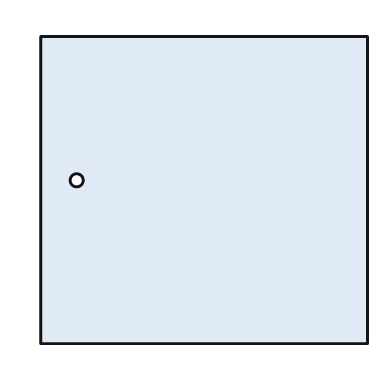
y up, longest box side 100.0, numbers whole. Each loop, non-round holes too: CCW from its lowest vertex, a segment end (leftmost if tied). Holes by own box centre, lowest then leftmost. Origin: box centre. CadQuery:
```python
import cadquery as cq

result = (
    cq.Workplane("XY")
    .moveTo(-50.0, -47.0)
    .lineTo(50.0, -47.0)
    .lineTo(50.0, 47.0)
    .lineTo(-50.0, 47.0)
    .close()
    .moveTo(-39.0, 3.0)
    .circle(2.0)
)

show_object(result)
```